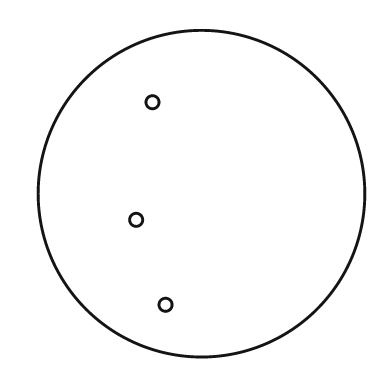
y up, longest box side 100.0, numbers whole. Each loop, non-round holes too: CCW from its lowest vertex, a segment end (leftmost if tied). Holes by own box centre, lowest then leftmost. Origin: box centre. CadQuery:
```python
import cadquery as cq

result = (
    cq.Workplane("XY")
    .moveTo(0.0, 0.0)
    .circle(50.0)
    .moveTo(-11.0, -34.0)
    .circle(2.0)
    .moveTo(-20.0, -8.0)
    .circle(2.0)
    .moveTo(-15.0, 28.0)
    .circle(2.0)
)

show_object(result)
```